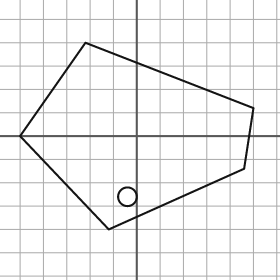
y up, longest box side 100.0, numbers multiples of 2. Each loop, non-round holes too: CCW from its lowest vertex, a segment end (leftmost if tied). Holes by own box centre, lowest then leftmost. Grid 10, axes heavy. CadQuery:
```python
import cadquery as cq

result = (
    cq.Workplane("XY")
    .moveTo(-12.0, -40.0)
    .lineTo(46.0, -14.0)
    .lineTo(50.0, 12.0)
    .lineTo(-22.0, 40.0)
    .lineTo(-50.0, 0.0)
    .close()
    .moveTo(-4.0, -26.0)
    .circle(4.0)
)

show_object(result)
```